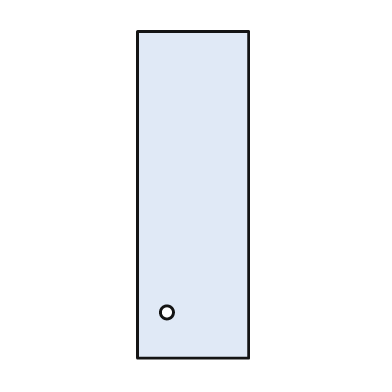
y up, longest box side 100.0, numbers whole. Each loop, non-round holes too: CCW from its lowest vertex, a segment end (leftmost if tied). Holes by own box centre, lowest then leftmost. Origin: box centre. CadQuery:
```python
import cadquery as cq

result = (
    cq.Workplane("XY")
    .moveTo(-17.0, -50.0)
    .lineTo(17.0, -50.0)
    .lineTo(17.0, 50.0)
    .lineTo(-17.0, 50.0)
    .close()
    .moveTo(-8.0, -36.0)
    .circle(2.0)
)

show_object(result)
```